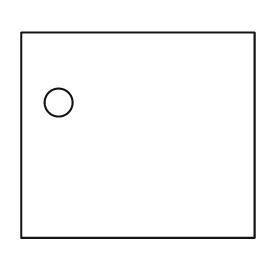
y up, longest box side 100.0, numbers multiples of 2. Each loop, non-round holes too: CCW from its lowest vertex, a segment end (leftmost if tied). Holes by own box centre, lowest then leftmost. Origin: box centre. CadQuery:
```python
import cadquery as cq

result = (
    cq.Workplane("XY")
    .moveTo(-50.0, -44.0)
    .lineTo(50.0, -44.0)
    .lineTo(50.0, 44.0)
    .lineTo(-50.0, 44.0)
    .close()
    .moveTo(-34.0, 14.0)
    .circle(6.0)
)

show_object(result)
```